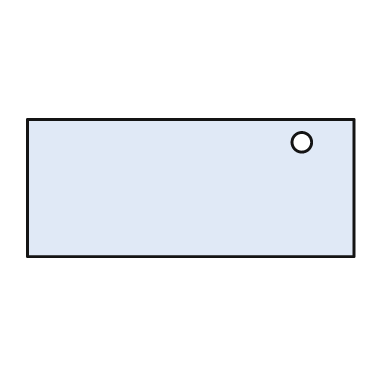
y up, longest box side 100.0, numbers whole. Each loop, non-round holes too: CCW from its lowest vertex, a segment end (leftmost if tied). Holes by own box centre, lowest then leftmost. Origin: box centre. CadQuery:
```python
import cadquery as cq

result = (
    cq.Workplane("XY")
    .moveTo(-50.0, -21.0)
    .lineTo(50.0, -21.0)
    .lineTo(50.0, 21.0)
    .lineTo(-50.0, 21.0)
    .close()
    .moveTo(34.0, 14.0)
    .circle(3.0)
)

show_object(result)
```